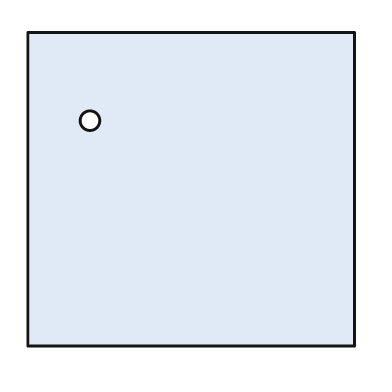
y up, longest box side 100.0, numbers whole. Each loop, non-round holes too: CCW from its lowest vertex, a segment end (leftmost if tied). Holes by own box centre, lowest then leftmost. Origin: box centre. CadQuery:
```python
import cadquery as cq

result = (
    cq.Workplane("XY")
    .moveTo(-50.0, -48.0)
    .lineTo(50.0, -48.0)
    .lineTo(50.0, 48.0)
    .lineTo(-50.0, 48.0)
    .close()
    .moveTo(-31.0, 21.0)
    .circle(3.0)
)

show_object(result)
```